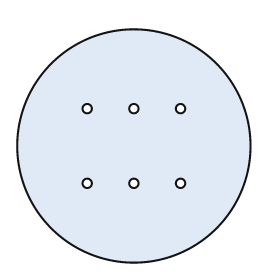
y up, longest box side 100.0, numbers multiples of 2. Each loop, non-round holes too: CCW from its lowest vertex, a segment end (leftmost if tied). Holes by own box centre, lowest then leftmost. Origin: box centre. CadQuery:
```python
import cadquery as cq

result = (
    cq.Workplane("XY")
    .moveTo(0.0, 0.0)
    .circle(50.0)
    .moveTo(-20.0, -16.0)
    .circle(2.0)
    .moveTo(0.0, -16.0)
    .circle(2.0)
    .moveTo(20.0, -16.0)
    .circle(2.0)
    .moveTo(-20.0, 16.0)
    .circle(2.0)
    .moveTo(0.0, 16.0)
    .circle(2.0)
    .moveTo(20.0, 16.0)
    .circle(2.0)
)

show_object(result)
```